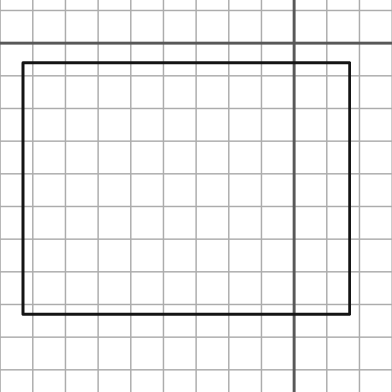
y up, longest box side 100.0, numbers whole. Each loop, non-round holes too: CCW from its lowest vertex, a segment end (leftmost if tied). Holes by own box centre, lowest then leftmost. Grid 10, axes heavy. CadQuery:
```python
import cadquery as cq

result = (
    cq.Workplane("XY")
    .moveTo(-83.0, -83.0)
    .lineTo(17.0, -83.0)
    .lineTo(17.0, -6.0)
    .lineTo(-83.0, -6.0)
    .close()
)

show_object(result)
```